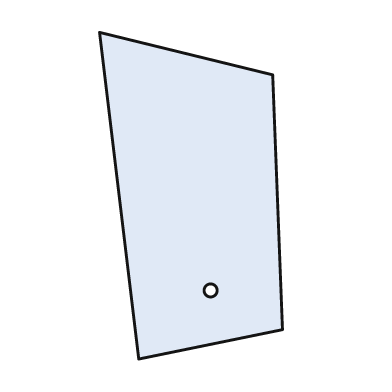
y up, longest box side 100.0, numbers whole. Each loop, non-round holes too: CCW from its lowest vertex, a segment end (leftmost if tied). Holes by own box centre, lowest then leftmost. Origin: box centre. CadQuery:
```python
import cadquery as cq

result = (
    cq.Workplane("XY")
    .moveTo(-16.0, -50.0)
    .lineTo(28.0, -41.0)
    .lineTo(25.0, 37.0)
    .lineTo(-28.0, 50.0)
    .close()
    .moveTo(6.0, -29.0)
    .circle(2.0)
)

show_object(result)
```